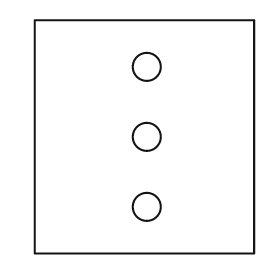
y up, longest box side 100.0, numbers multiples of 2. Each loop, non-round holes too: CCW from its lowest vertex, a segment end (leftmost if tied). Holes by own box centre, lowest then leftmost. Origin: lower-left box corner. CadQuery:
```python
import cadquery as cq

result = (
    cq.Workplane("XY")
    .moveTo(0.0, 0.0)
    .lineTo(94.0, 0.0)
    .lineTo(94.0, 100.0)
    .lineTo(0.0, 100.0)
    .close()
    .moveTo(48.0, 20.0)
    .circle(6.0)
    .moveTo(48.0, 50.0)
    .circle(6.0)
    .moveTo(48.0, 80.0)
    .circle(6.0)
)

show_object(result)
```